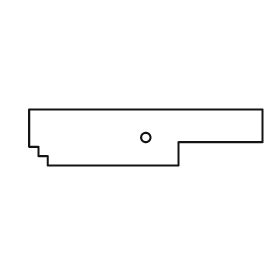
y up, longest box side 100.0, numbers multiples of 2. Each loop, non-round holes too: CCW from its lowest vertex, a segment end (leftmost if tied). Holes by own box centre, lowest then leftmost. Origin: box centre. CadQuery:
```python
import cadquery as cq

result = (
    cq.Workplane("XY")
    .moveTo(-42.0, -12.0)
    .lineTo(14.0, -12.0)
    .lineTo(14.0, -2.0)
    .lineTo(50.0, -2.0)
    .lineTo(50.0, 12.0)
    .lineTo(-50.0, 12.0)
    .lineTo(-50.0, -4.0)
    .lineTo(-46.0, -4.0)
    .lineTo(-46.0, -8.0)
    .lineTo(-42.0, -8.0)
    .close()
    .moveTo(0.0, 0.0)
    .circle(2.0)
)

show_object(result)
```